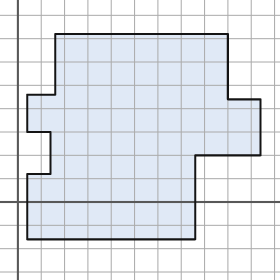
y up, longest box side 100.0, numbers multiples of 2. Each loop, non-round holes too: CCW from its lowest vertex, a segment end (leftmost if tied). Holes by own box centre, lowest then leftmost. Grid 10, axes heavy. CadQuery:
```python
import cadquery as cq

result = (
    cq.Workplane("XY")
    .moveTo(4.0, -16.0)
    .lineTo(76.0, -16.0)
    .lineTo(76.0, 20.0)
    .lineTo(104.0, 20.0)
    .lineTo(104.0, 44.0)
    .lineTo(90.0, 44.0)
    .lineTo(90.0, 72.0)
    .lineTo(16.0, 72.0)
    .lineTo(16.0, 46.0)
    .lineTo(4.0, 46.0)
    .lineTo(4.0, 30.0)
    .lineTo(14.0, 30.0)
    .lineTo(14.0, 12.0)
    .lineTo(4.0, 12.0)
    .close()
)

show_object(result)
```